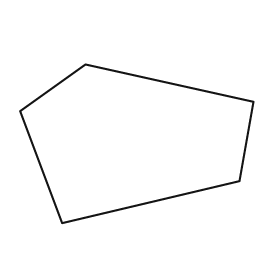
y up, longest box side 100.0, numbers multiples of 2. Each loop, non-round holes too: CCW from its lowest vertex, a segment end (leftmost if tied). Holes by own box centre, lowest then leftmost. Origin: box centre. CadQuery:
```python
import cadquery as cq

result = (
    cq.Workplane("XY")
    .moveTo(-32.0, -34.0)
    .lineTo(44.0, -16.0)
    .lineTo(50.0, 18.0)
    .lineTo(-22.0, 34.0)
    .lineTo(-50.0, 14.0)
    .close()
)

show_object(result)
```